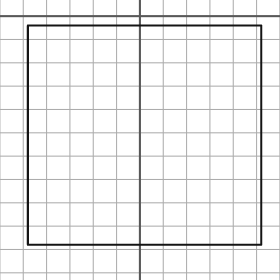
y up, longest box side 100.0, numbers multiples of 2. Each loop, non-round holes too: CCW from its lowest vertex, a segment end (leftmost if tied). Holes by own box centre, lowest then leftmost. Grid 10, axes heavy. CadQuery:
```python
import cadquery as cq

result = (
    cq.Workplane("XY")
    .moveTo(-48.0, -98.0)
    .lineTo(52.0, -98.0)
    .lineTo(52.0, -4.0)
    .lineTo(-48.0, -4.0)
    .close()
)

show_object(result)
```